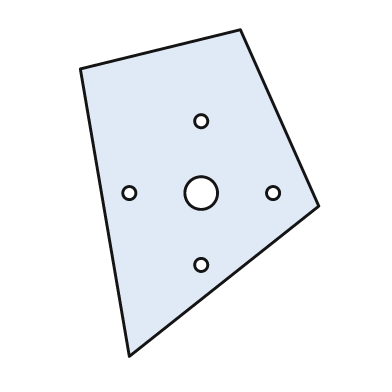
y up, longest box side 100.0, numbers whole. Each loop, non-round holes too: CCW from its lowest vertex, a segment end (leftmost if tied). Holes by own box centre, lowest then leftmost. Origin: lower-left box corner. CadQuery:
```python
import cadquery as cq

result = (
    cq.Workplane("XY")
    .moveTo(15.0, 0.0)
    .lineTo(73.0, 46.0)
    .lineTo(49.0, 100.0)
    .lineTo(0.0, 88.0)
    .close()
    .moveTo(37.0, 28.0)
    .circle(2.0)
    .moveTo(15.0, 50.0)
    .circle(2.0)
    .moveTo(37.0, 50.0)
    .circle(5.0)
    .moveTo(59.0, 50.0)
    .circle(2.0)
    .moveTo(37.0, 72.0)
    .circle(2.0)
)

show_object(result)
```